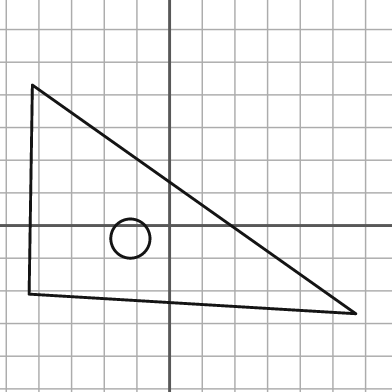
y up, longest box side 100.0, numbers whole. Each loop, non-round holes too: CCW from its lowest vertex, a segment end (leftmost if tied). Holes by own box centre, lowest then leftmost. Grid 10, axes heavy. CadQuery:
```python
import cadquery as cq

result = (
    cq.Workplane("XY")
    .moveTo(57.0, -27.0)
    .lineTo(-42.0, 43.0)
    .lineTo(-43.0, -21.0)
    .close()
    .moveTo(-12.0, -4.0)
    .circle(6.0)
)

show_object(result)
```